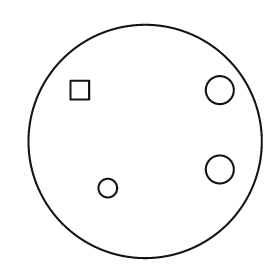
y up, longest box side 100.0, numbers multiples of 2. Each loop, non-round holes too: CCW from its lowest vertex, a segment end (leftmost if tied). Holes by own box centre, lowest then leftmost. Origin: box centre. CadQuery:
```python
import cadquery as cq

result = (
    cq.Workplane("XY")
    .moveTo(0.0, 0.0)
    .circle(50.0)
    .moveTo(-16.0, -20.0)
    .circle(4.0)
    .moveTo(32.0, -12.0)
    .circle(6.0)
    .moveTo(-32.0, 18.0)
    .lineTo(-24.0, 18.0)
    .lineTo(-24.0, 26.0)
    .lineTo(-32.0, 26.0)
    .close()
    .moveTo(32.0, 22.0)
    .circle(6.0)
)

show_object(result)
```